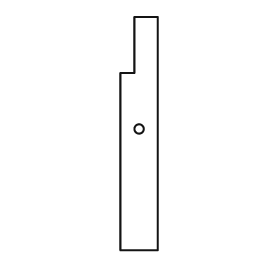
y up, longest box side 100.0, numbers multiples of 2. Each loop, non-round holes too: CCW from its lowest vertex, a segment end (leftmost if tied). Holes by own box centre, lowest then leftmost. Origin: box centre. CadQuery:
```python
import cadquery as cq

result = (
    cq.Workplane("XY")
    .moveTo(-8.0, -50.0)
    .lineTo(8.0, -50.0)
    .lineTo(8.0, 50.0)
    .lineTo(-2.0, 50.0)
    .lineTo(-2.0, 26.0)
    .lineTo(-8.0, 26.0)
    .close()
    .moveTo(0.0, 2.0)
    .circle(2.0)
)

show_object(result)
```